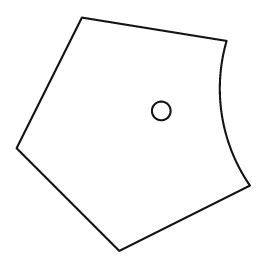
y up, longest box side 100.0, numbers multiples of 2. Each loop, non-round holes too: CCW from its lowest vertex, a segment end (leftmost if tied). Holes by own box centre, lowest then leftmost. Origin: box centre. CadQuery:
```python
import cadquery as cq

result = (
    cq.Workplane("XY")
    .moveTo(-6.0, -50.0)
    .lineTo(50.0, -22.0)
    .threePointArc((38.0, 8.0), (40.0, 40.0))
    .lineTo(-22.0, 50.0)
    .lineTo(-50.0, -6.0)
    .close()
    .moveTo(12.0, 10.0)
    .circle(4.0)
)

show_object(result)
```